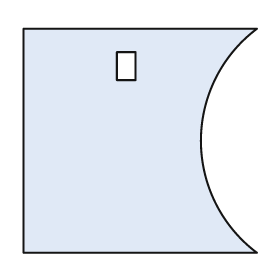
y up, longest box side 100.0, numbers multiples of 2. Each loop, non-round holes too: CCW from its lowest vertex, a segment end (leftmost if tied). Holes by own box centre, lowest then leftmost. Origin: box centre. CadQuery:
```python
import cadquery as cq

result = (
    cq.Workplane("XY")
    .moveTo(-50.0, -48.0)
    .lineTo(50.0, -48.0)
    .threePointArc((26.0, 0.0), (50.0, 48.0))
    .lineTo(-50.0, 48.0)
    .close()
    .moveTo(-10.0, 26.0)
    .lineTo(-2.0, 26.0)
    .lineTo(-2.0, 38.0)
    .lineTo(-10.0, 38.0)
    .close()
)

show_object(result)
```